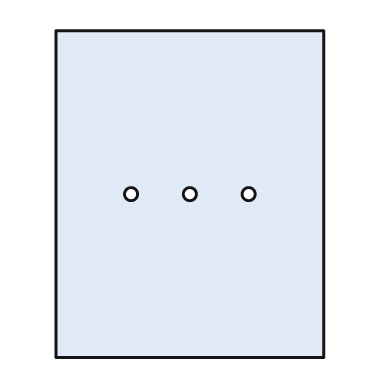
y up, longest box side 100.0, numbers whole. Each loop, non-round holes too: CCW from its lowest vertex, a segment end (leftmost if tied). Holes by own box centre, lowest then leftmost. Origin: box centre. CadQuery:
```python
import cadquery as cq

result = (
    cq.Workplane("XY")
    .moveTo(-41.0, -50.0)
    .lineTo(41.0, -50.0)
    .lineTo(41.0, 50.0)
    .lineTo(-41.0, 50.0)
    .close()
    .moveTo(-18.0, 0.0)
    .circle(2.0)
    .moveTo(0.0, 0.0)
    .circle(2.0)
    .moveTo(18.0, 0.0)
    .circle(2.0)
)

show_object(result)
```